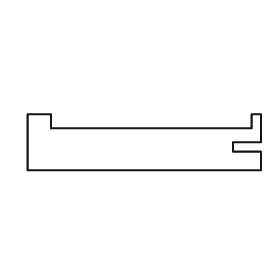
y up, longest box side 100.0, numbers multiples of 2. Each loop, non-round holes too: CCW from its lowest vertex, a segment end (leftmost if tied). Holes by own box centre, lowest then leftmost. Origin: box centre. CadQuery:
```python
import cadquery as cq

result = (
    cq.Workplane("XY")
    .moveTo(-50.0, -12.0)
    .lineTo(50.0, -12.0)
    .lineTo(50.0, -4.0)
    .lineTo(38.0, -4.0)
    .lineTo(38.0, 0.0)
    .lineTo(50.0, 0.0)
    .lineTo(50.0, 12.0)
    .lineTo(46.0, 12.0)
    .lineTo(46.0, 6.0)
    .lineTo(-40.0, 6.0)
    .lineTo(-40.0, 12.0)
    .lineTo(-50.0, 12.0)
    .close()
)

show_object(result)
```